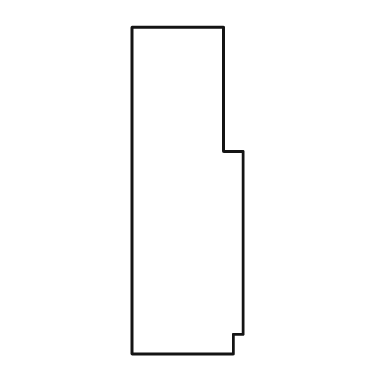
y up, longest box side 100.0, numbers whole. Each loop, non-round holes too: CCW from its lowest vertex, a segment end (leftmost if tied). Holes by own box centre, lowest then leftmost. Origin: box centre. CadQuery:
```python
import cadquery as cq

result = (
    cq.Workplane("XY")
    .moveTo(-17.0, -50.0)
    .lineTo(14.0, -50.0)
    .lineTo(14.0, -44.0)
    .lineTo(17.0, -44.0)
    .lineTo(17.0, 12.0)
    .lineTo(11.0, 12.0)
    .lineTo(11.0, 50.0)
    .lineTo(-17.0, 50.0)
    .close()
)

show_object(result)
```